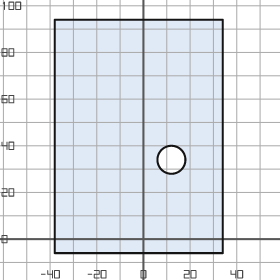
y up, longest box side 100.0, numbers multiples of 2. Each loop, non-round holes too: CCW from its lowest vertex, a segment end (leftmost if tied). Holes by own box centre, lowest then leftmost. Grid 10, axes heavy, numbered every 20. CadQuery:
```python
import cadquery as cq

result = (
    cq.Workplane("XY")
    .moveTo(-38.0, -6.0)
    .lineTo(34.0, -6.0)
    .lineTo(34.0, 94.0)
    .lineTo(-38.0, 94.0)
    .close()
    .moveTo(12.0, 34.0)
    .circle(6.0)
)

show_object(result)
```